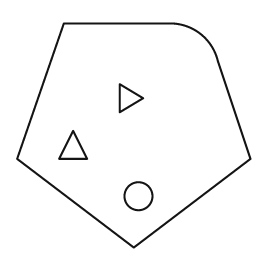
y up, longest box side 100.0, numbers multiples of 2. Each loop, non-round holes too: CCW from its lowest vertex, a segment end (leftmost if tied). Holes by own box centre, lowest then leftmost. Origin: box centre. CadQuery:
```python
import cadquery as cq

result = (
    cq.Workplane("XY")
    .moveTo(0.0, -48.0)
    .lineTo(50.0, -10.0)
    .lineTo(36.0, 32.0)
    .threePointArc((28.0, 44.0), (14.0, 48.0))
    .lineTo(-30.0, 48.0)
    .lineTo(-50.0, -10.0)
    .close()
    .moveTo(2.0, -26.0)
    .circle(6.0)
    .moveTo(-32.0, -10.0)
    .lineTo(-20.0, -10.0)
    .lineTo(-26.0, 2.0)
    .close()
    .moveTo(-6.0, 10.0)
    .lineTo(4.0, 16.0)
    .lineTo(-6.0, 22.0)
    .close()
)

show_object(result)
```